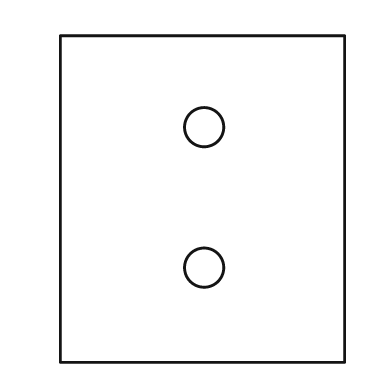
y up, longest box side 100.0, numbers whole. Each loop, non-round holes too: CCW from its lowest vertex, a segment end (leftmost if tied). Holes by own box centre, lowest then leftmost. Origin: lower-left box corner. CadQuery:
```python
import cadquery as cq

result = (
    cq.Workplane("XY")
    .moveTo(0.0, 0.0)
    .lineTo(87.0, 0.0)
    .lineTo(87.0, 100.0)
    .lineTo(0.0, 100.0)
    .close()
    .moveTo(44.0, 29.0)
    .circle(6.0)
    .moveTo(44.0, 72.0)
    .circle(6.0)
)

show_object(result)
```